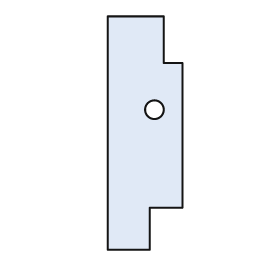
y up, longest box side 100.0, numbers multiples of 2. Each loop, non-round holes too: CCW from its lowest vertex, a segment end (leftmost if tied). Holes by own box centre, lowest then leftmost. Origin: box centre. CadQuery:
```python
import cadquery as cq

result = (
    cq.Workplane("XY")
    .moveTo(-16.0, -50.0)
    .lineTo(2.0, -50.0)
    .lineTo(2.0, -32.0)
    .lineTo(16.0, -32.0)
    .lineTo(16.0, 30.0)
    .lineTo(8.0, 30.0)
    .lineTo(8.0, 50.0)
    .lineTo(-16.0, 50.0)
    .close()
    .moveTo(4.0, 10.0)
    .circle(4.0)
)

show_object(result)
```